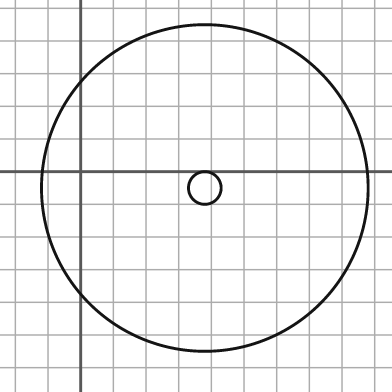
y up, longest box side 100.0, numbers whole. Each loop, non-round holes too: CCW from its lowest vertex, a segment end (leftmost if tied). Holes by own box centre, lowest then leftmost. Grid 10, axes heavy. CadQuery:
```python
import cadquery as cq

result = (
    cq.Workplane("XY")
    .moveTo(38.0, -5.0)
    .circle(50.0)
    .moveTo(38.0, -5.0)
    .circle(5.0)
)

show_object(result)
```